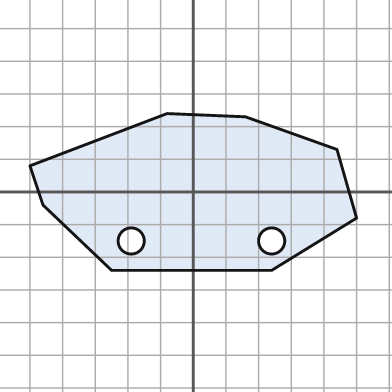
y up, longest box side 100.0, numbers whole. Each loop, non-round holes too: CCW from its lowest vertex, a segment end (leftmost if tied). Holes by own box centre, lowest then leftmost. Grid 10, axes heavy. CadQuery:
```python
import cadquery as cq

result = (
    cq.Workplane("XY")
    .moveTo(-25.0, -24.0)
    .lineTo(24.0, -24.0)
    .lineTo(50.0, -8.0)
    .lineTo(44.0, 13.0)
    .lineTo(16.0, 23.0)
    .lineTo(-8.0, 24.0)
    .lineTo(-50.0, 8.0)
    .lineTo(-46.0, -4.0)
    .close()
    .moveTo(-19.0, -15.0)
    .circle(4.0)
    .moveTo(24.0, -15.0)
    .circle(4.0)
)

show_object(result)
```